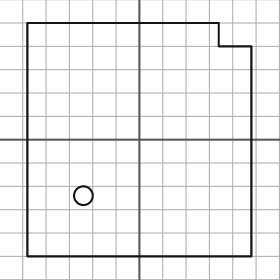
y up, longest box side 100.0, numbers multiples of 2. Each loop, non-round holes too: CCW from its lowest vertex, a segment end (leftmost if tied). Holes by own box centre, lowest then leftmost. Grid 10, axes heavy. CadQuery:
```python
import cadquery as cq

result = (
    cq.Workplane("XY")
    .moveTo(-48.0, -50.0)
    .lineTo(48.0, -50.0)
    .lineTo(48.0, 40.0)
    .lineTo(34.0, 40.0)
    .lineTo(34.0, 50.0)
    .lineTo(-48.0, 50.0)
    .close()
    .moveTo(-24.0, -24.0)
    .circle(4.0)
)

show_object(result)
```